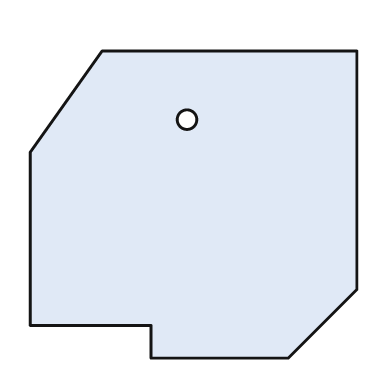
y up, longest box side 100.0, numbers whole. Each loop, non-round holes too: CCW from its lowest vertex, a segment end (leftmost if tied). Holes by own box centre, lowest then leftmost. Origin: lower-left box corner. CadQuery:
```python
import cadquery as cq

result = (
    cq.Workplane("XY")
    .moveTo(37.0, 0.0)
    .lineTo(79.0, 0.0)
    .lineTo(100.0, 21.0)
    .lineTo(100.0, 94.0)
    .lineTo(22.0, 94.0)
    .lineTo(0.0, 63.0)
    .lineTo(0.0, 10.0)
    .lineTo(37.0, 10.0)
    .close()
    .moveTo(48.0, 73.0)
    .circle(3.0)
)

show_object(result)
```